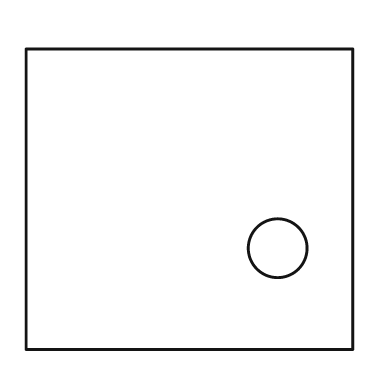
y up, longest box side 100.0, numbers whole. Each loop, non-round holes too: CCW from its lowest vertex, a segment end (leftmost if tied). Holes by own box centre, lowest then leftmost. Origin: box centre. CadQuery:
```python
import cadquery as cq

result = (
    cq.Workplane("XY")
    .moveTo(-50.0, -46.0)
    .lineTo(50.0, -46.0)
    .lineTo(50.0, 46.0)
    .lineTo(-50.0, 46.0)
    .close()
    .moveTo(27.0, -15.0)
    .circle(9.0)
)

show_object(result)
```